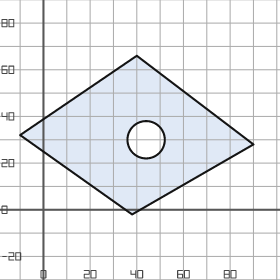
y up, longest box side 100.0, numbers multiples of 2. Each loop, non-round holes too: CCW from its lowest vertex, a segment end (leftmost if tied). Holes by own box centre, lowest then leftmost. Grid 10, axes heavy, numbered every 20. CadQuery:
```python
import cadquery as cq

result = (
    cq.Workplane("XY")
    .moveTo(38.0, -2.0)
    .lineTo(90.0, 28.0)
    .lineTo(40.0, 66.0)
    .lineTo(-10.0, 32.0)
    .close()
    .moveTo(44.0, 30.0)
    .circle(8.0)
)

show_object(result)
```